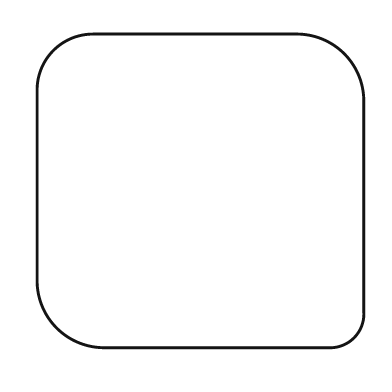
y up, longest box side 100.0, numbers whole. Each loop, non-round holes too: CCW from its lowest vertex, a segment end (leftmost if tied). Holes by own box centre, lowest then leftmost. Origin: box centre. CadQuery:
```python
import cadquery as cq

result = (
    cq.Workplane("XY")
    .moveTo(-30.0, -48.0)
    .lineTo(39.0, -48.0)
    .threePointArc((47.0, -45.0), (50.0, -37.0))
    .lineTo(50.0, 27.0)
    .threePointArc((44.0, 42.0), (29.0, 48.0))
    .lineTo(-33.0, 48.0)
    .threePointArc((-45.0, 43.0), (-50.0, 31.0))
    .lineTo(-50.0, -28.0)
    .threePointArc((-44.0, -42.0), (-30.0, -48.0))
    .close()
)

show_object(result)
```